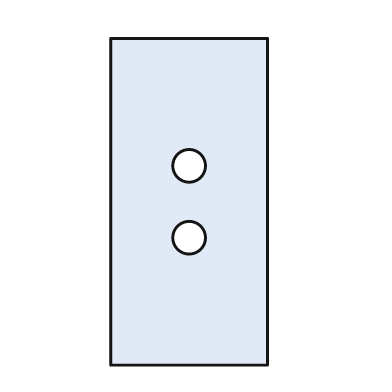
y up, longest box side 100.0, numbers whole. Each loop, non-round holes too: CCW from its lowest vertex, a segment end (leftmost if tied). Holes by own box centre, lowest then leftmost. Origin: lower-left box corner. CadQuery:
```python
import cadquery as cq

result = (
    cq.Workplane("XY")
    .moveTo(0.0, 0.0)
    .lineTo(48.0, 0.0)
    .lineTo(48.0, 100.0)
    .lineTo(0.0, 100.0)
    .close()
    .moveTo(24.0, 39.0)
    .circle(5.0)
    .moveTo(24.0, 61.0)
    .circle(5.0)
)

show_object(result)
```